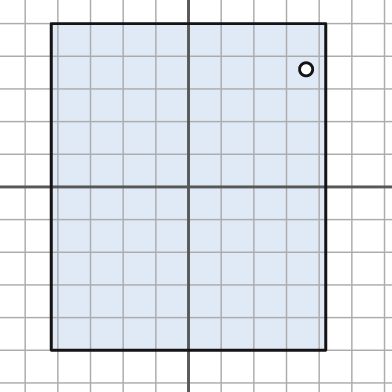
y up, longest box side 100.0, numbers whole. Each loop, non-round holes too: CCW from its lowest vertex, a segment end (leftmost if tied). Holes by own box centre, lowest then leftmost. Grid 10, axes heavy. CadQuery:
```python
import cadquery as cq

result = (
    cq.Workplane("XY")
    .moveTo(-42.0, -50.0)
    .lineTo(42.0, -50.0)
    .lineTo(42.0, 50.0)
    .lineTo(-42.0, 50.0)
    .close()
    .moveTo(36.0, 36.0)
    .circle(2.0)
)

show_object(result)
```